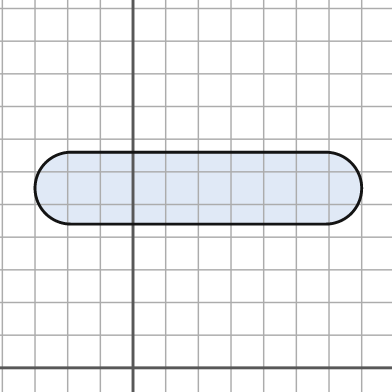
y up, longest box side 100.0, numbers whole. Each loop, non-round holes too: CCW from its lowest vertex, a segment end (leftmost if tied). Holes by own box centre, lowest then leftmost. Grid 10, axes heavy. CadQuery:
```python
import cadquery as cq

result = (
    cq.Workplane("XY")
    .moveTo(-19.0, 44.0)
    .lineTo(59.0, 44.0)
    .threePointArc((70.0, 55.0), (59.0, 66.0))
    .lineTo(-19.0, 66.0)
    .threePointArc((-30.0, 55.0), (-19.0, 44.0))
    .close()
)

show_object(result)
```